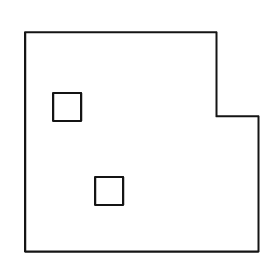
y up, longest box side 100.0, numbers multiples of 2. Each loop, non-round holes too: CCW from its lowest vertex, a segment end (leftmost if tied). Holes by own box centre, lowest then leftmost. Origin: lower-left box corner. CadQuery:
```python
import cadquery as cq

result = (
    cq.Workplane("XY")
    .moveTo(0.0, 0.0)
    .lineTo(100.0, 0.0)
    .lineTo(100.0, 58.0)
    .lineTo(82.0, 58.0)
    .lineTo(82.0, 94.0)
    .lineTo(0.0, 94.0)
    .close()
    .moveTo(30.0, 20.0)
    .lineTo(42.0, 20.0)
    .lineTo(42.0, 32.0)
    .lineTo(30.0, 32.0)
    .close()
    .moveTo(12.0, 56.0)
    .lineTo(24.0, 56.0)
    .lineTo(24.0, 68.0)
    .lineTo(12.0, 68.0)
    .close()
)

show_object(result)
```